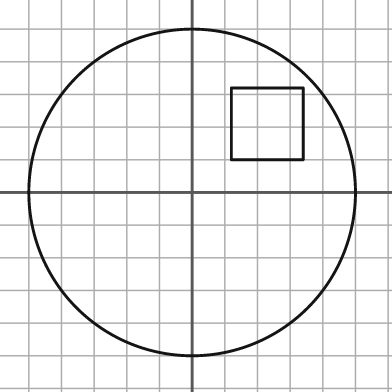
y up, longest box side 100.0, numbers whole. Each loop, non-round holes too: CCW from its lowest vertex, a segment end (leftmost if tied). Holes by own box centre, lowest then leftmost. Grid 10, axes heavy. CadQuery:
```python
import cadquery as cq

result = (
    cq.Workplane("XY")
    .moveTo(0.0, 0.0)
    .circle(50.0)
    .moveTo(12.0, 10.0)
    .lineTo(34.0, 10.0)
    .lineTo(34.0, 32.0)
    .lineTo(12.0, 32.0)
    .close()
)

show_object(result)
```